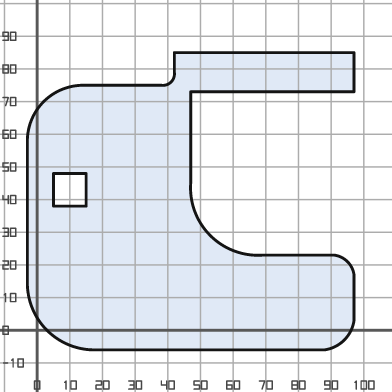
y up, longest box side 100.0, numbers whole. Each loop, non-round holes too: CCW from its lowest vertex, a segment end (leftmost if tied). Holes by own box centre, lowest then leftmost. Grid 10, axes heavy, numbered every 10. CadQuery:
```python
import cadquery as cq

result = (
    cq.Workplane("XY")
    .moveTo(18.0, -6.0)
    .lineTo(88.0, -6.0)
    .threePointArc((94.0, -3.0), (97.0, 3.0))
    .lineTo(97.0, 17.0)
    .threePointArc((95.0, 21.0), (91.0, 23.0))
    .lineTo(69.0, 23.0)
    .threePointArc((53.0, 29.0), (47.0, 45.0))
    .lineTo(47.0, 73.0)
    .lineTo(97.0, 73.0)
    .lineTo(97.0, 85.0)
    .lineTo(42.0, 85.0)
    .lineTo(42.0, 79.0)
    .threePointArc((41.0, 76.0), (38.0, 75.0))
    .lineTo(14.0, 75.0)
    .threePointArc((2.0, 70.0), (-3.0, 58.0))
    .lineTo(-3.0, 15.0)
    .threePointArc((3.0, 0.0), (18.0, -6.0))
    .close()
    .moveTo(5.0, 38.0)
    .lineTo(15.0, 38.0)
    .lineTo(15.0, 48.0)
    .lineTo(5.0, 48.0)
    .close()
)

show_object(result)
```